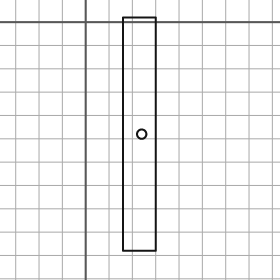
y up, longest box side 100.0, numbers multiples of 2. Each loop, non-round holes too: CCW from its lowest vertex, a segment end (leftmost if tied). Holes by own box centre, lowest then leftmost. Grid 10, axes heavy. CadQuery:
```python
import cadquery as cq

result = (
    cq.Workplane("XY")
    .moveTo(16.0, -98.0)
    .lineTo(30.0, -98.0)
    .lineTo(30.0, 2.0)
    .lineTo(16.0, 2.0)
    .close()
    .moveTo(24.0, -48.0)
    .circle(2.0)
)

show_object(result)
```